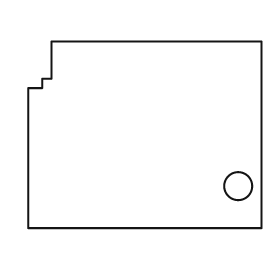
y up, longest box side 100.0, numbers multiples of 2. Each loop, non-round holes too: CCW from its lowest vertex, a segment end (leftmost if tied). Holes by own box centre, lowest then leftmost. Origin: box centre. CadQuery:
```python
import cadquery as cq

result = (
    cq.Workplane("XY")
    .moveTo(-50.0, -40.0)
    .lineTo(50.0, -40.0)
    .lineTo(50.0, 40.0)
    .lineTo(-40.0, 40.0)
    .lineTo(-40.0, 24.0)
    .lineTo(-44.0, 24.0)
    .lineTo(-44.0, 20.0)
    .lineTo(-50.0, 20.0)
    .close()
    .moveTo(40.0, -22.0)
    .circle(6.0)
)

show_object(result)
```